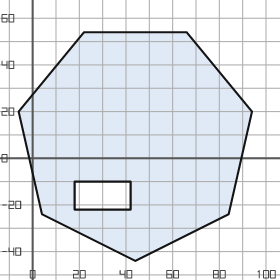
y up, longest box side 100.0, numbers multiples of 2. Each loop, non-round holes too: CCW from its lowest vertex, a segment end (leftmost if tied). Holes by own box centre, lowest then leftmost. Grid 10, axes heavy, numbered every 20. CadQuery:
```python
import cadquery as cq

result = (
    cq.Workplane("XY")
    .moveTo(44.0, -44.0)
    .lineTo(84.0, -24.0)
    .lineTo(94.0, 20.0)
    .lineTo(66.0, 54.0)
    .lineTo(22.0, 54.0)
    .lineTo(-6.0, 20.0)
    .lineTo(4.0, -24.0)
    .close()
    .moveTo(18.0, -22.0)
    .lineTo(42.0, -22.0)
    .lineTo(42.0, -10.0)
    .lineTo(18.0, -10.0)
    .close()
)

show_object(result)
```